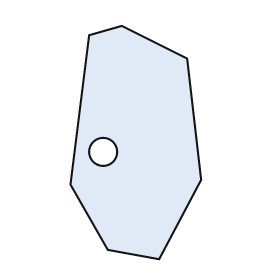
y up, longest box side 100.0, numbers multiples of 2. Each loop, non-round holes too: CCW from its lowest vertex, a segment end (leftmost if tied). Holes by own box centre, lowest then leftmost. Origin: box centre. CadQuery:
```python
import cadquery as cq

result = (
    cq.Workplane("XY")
    .moveTo(10.0, -50.0)
    .lineTo(28.0, -16.0)
    .lineTo(22.0, 36.0)
    .lineTo(-6.0, 50.0)
    .lineTo(-20.0, 46.0)
    .lineTo(-28.0, -18.0)
    .lineTo(-12.0, -46.0)
    .close()
    .moveTo(-14.0, -4.0)
    .circle(6.0)
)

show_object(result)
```